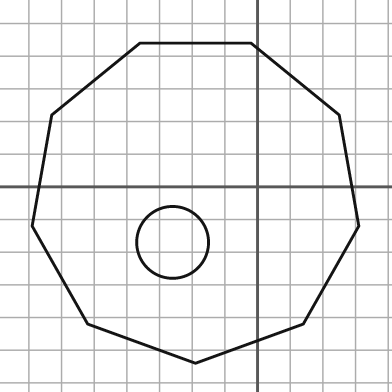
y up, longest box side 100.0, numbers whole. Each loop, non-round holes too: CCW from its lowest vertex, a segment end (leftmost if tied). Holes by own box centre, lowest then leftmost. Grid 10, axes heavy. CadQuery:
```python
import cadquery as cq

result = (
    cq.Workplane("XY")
    .moveTo(-19.0, -54.0)
    .lineTo(14.0, -42.0)
    .lineTo(31.0, -12.0)
    .lineTo(25.0, 22.0)
    .lineTo(-2.0, 44.0)
    .lineTo(-36.0, 44.0)
    .lineTo(-63.0, 22.0)
    .lineTo(-69.0, -12.0)
    .lineTo(-52.0, -42.0)
    .close()
    .moveTo(-26.0, -17.0)
    .circle(11.0)
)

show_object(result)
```